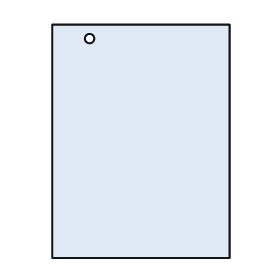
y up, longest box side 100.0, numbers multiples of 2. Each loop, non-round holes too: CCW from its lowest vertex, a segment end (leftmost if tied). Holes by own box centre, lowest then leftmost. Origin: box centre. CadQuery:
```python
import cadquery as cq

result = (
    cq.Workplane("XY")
    .moveTo(-38.0, -50.0)
    .lineTo(38.0, -50.0)
    .lineTo(38.0, 50.0)
    .lineTo(-38.0, 50.0)
    .close()
    .moveTo(-22.0, 44.0)
    .circle(2.0)
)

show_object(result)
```